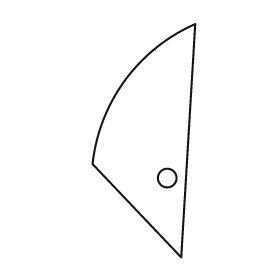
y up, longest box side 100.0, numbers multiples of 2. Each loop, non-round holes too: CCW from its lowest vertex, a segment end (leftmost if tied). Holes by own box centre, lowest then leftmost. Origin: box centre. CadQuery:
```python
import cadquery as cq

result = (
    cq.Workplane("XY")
    .moveTo(16.0, -50.0)
    .lineTo(22.0, 50.0)
    .threePointArc((-8.0, 26.0), (-22.0, -10.0))
    .close()
    .moveTo(10.0, -16.0)
    .circle(4.0)
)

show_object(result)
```